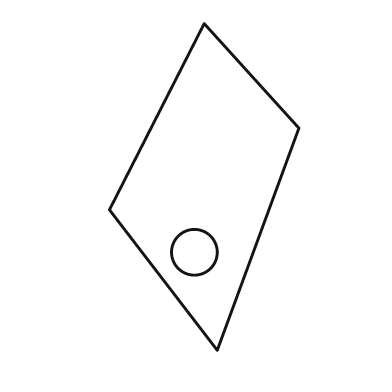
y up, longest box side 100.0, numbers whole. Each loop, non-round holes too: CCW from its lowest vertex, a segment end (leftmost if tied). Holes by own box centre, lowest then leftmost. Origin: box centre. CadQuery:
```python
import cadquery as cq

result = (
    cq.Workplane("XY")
    .moveTo(4.0, -50.0)
    .lineTo(29.0, 18.0)
    .lineTo(0.0, 50.0)
    .lineTo(-29.0, -7.0)
    .close()
    .moveTo(-3.0, -20.0)
    .circle(7.0)
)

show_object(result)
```